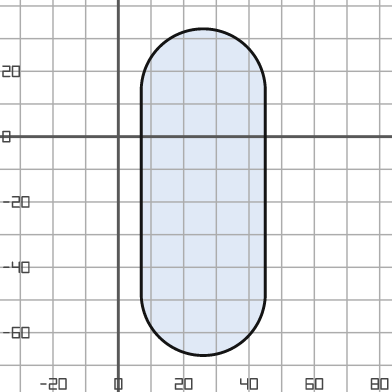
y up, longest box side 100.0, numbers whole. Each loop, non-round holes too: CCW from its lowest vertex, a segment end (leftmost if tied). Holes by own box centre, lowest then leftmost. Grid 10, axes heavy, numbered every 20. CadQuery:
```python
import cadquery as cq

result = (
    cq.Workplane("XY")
    .moveTo(7.0, -48.0)
    .threePointArc((26.0, -67.0), (45.0, -48.0))
    .lineTo(45.0, 14.0)
    .threePointArc((26.0, 33.0), (7.0, 14.0))
    .close()
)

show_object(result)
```